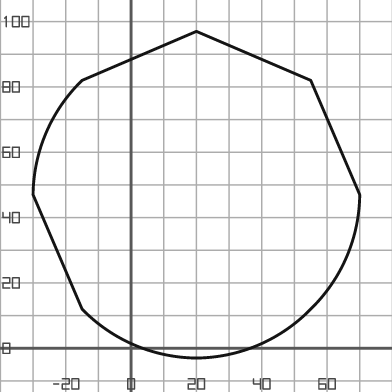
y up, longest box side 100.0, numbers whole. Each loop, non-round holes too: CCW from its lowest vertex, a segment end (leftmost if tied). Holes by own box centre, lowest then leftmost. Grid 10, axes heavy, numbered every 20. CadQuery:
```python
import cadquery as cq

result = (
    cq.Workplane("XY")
    .moveTo(20.0, -3.0)
    .threePointArc((39.0, 1.0), (55.0, 12.0))
    .threePointArc((66.0, 28.0), (70.0, 47.0))
    .lineTo(55.0, 82.0)
    .lineTo(20.0, 97.0)
    .lineTo(-15.0, 82.0)
    .threePointArc((-26.0, 66.0), (-30.0, 47.0))
    .lineTo(-15.0, 12.0)
    .threePointArc((1.0, 1.0), (20.0, -3.0))
    .close()
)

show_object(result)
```